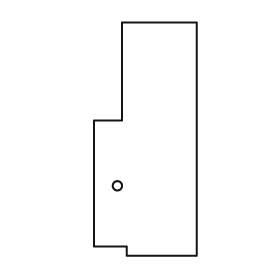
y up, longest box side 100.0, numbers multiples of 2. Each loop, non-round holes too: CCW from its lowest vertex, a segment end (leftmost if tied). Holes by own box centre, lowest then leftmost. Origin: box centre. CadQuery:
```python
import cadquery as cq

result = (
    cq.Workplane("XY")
    .moveTo(-8.0, -50.0)
    .lineTo(22.0, -50.0)
    .lineTo(22.0, 50.0)
    .lineTo(-10.0, 50.0)
    .lineTo(-10.0, 8.0)
    .lineTo(-22.0, 8.0)
    .lineTo(-22.0, -46.0)
    .lineTo(-8.0, -46.0)
    .close()
    .moveTo(-12.0, -20.0)
    .circle(2.0)
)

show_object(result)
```